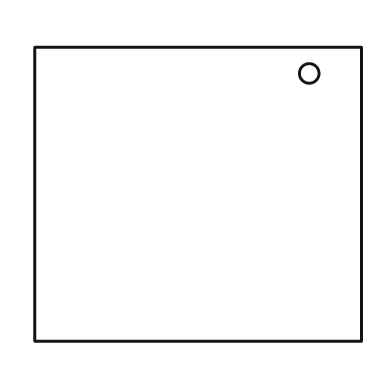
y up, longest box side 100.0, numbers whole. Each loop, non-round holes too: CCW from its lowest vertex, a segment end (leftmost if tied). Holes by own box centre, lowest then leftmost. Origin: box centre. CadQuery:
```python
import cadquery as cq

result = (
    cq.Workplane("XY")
    .moveTo(-50.0, -45.0)
    .lineTo(50.0, -45.0)
    .lineTo(50.0, 45.0)
    .lineTo(-50.0, 45.0)
    .close()
    .moveTo(34.0, 37.0)
    .circle(3.0)
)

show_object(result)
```